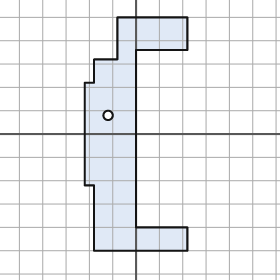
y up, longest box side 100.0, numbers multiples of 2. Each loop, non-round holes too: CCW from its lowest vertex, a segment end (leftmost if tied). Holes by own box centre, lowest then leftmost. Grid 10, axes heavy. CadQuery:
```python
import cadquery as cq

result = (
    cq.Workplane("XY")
    .moveTo(-18.0, -50.0)
    .lineTo(22.0, -50.0)
    .lineTo(22.0, -40.0)
    .lineTo(0.0, -40.0)
    .lineTo(0.0, 36.0)
    .lineTo(22.0, 36.0)
    .lineTo(22.0, 50.0)
    .lineTo(-8.0, 50.0)
    .lineTo(-8.0, 32.0)
    .lineTo(-18.0, 32.0)
    .lineTo(-18.0, 22.0)
    .lineTo(-22.0, 22.0)
    .lineTo(-22.0, -22.0)
    .lineTo(-18.0, -22.0)
    .close()
    .moveTo(-12.0, 8.0)
    .circle(2.0)
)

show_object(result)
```